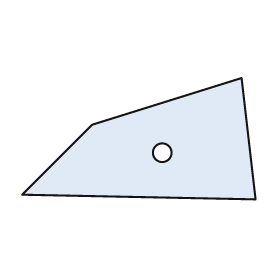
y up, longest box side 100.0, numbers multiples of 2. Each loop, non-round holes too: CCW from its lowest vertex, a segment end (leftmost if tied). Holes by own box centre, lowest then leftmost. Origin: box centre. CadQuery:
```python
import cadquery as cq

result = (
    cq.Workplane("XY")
    .moveTo(50.0, -26.0)
    .lineTo(44.0, 26.0)
    .lineTo(-20.0, 6.0)
    .lineTo(-50.0, -24.0)
    .close()
    .moveTo(10.0, -6.0)
    .circle(4.0)
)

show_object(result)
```